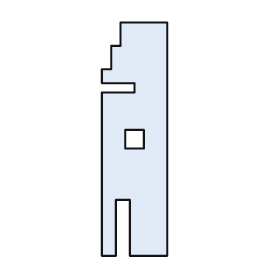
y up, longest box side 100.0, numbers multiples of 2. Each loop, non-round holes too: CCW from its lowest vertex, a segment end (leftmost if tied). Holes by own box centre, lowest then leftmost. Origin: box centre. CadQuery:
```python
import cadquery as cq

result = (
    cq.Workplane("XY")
    .moveTo(-14.0, -50.0)
    .lineTo(-8.0, -50.0)
    .lineTo(-8.0, -26.0)
    .lineTo(-2.0, -26.0)
    .lineTo(-2.0, -50.0)
    .lineTo(14.0, -50.0)
    .lineTo(14.0, 50.0)
    .lineTo(-6.0, 50.0)
    .lineTo(-6.0, 40.0)
    .lineTo(-10.0, 40.0)
    .lineTo(-10.0, 30.0)
    .lineTo(-14.0, 30.0)
    .lineTo(-14.0, 24.0)
    .lineTo(0.0, 24.0)
    .lineTo(0.0, 20.0)
    .lineTo(-14.0, 20.0)
    .close()
    .moveTo(-4.0, -4.0)
    .lineTo(4.0, -4.0)
    .lineTo(4.0, 4.0)
    .lineTo(-4.0, 4.0)
    .close()
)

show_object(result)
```